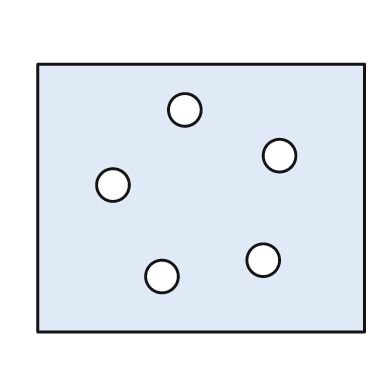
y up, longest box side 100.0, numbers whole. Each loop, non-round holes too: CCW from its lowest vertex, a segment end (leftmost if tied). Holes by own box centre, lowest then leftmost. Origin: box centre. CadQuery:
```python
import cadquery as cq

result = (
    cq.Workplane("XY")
    .moveTo(-50.0, -41.0)
    .lineTo(50.0, -41.0)
    .lineTo(50.0, 41.0)
    .lineTo(-50.0, 41.0)
    .close()
    .moveTo(-12.0, -24.0)
    .circle(5.0)
    .moveTo(19.0, -19.0)
    .circle(5.0)
    .moveTo(-27.0, 4.0)
    .circle(5.0)
    .moveTo(24.0, 13.0)
    .circle(5.0)
    .moveTo(-5.0, 27.0)
    .circle(5.0)
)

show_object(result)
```